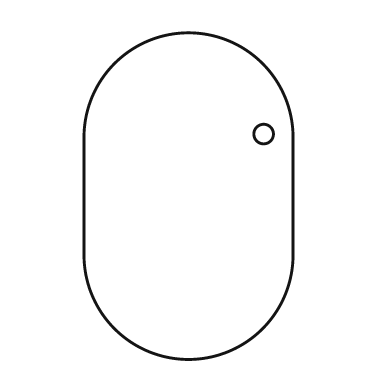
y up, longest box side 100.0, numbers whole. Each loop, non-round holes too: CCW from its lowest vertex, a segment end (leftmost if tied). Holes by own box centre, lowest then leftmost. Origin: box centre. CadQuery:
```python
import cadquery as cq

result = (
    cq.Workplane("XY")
    .moveTo(-32.0, -18.0)
    .threePointArc((0.0, -50.0), (32.0, -18.0))
    .lineTo(32.0, 18.0)
    .threePointArc((0.0, 50.0), (-32.0, 18.0))
    .close()
    .moveTo(23.0, 19.0)
    .circle(3.0)
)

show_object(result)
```